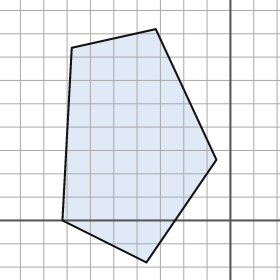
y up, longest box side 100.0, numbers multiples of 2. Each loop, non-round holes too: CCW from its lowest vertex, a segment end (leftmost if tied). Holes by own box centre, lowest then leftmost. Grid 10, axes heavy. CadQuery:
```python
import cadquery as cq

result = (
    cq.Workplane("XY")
    .moveTo(-36.0, -18.0)
    .lineTo(-6.0, 26.0)
    .lineTo(-32.0, 82.0)
    .lineTo(-68.0, 74.0)
    .lineTo(-72.0, 0.0)
    .close()
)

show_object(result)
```